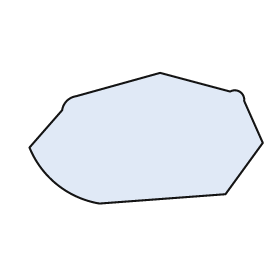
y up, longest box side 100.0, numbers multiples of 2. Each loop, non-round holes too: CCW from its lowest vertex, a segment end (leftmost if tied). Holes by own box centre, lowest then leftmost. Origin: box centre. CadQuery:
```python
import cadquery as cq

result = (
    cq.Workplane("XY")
    .moveTo(-20.0, -28.0)
    .lineTo(34.0, -24.0)
    .lineTo(50.0, -2.0)
    .lineTo(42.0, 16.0)
    .threePointArc((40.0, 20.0), (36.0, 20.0))
    .lineTo(6.0, 28.0)
    .lineTo(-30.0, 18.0)
    .threePointArc((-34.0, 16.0), (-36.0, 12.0))
    .lineTo(-50.0, -4.0)
    .threePointArc((-38.0, -20.0), (-20.0, -28.0))
    .close()
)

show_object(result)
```